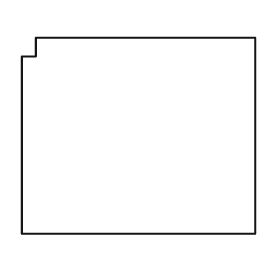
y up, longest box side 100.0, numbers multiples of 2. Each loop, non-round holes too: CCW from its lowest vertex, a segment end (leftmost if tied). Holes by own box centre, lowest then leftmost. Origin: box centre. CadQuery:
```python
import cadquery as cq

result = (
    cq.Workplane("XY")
    .moveTo(-50.0, -42.0)
    .lineTo(50.0, -42.0)
    .lineTo(50.0, 42.0)
    .lineTo(-44.0, 42.0)
    .lineTo(-44.0, 34.0)
    .lineTo(-50.0, 34.0)
    .close()
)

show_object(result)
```